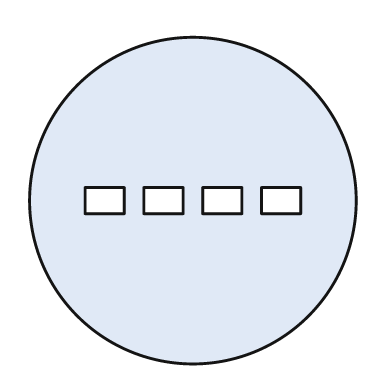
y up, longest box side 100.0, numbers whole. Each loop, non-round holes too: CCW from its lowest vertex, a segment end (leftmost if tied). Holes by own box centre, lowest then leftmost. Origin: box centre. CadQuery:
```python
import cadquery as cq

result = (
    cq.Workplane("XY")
    .moveTo(0.0, 0.0)
    .circle(50.0)
    .moveTo(-33.0, -4.0)
    .lineTo(-21.0, -4.0)
    .lineTo(-21.0, 4.0)
    .lineTo(-33.0, 4.0)
    .close()
    .moveTo(-15.0, -4.0)
    .lineTo(-3.0, -4.0)
    .lineTo(-3.0, 4.0)
    .lineTo(-15.0, 4.0)
    .close()
    .moveTo(3.0, -4.0)
    .lineTo(15.0, -4.0)
    .lineTo(15.0, 4.0)
    .lineTo(3.0, 4.0)
    .close()
    .moveTo(21.0, -4.0)
    .lineTo(33.0, -4.0)
    .lineTo(33.0, 4.0)
    .lineTo(21.0, 4.0)
    .close()
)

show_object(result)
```